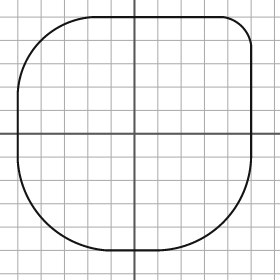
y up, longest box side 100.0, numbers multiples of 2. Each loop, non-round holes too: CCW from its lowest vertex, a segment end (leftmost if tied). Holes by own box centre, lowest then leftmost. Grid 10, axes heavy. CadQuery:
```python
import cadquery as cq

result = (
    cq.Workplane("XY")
    .moveTo(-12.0, -50.0)
    .lineTo(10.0, -50.0)
    .threePointArc((38.0, -38.0), (50.0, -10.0))
    .lineTo(50.0, 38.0)
    .threePointArc((46.0, 46.0), (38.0, 50.0))
    .lineTo(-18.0, 50.0)
    .threePointArc((-40.0, 40.0), (-50.0, 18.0))
    .lineTo(-50.0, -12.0)
    .threePointArc((-38.0, -38.0), (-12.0, -50.0))
    .close()
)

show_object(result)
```